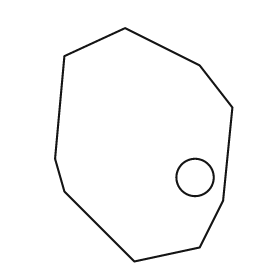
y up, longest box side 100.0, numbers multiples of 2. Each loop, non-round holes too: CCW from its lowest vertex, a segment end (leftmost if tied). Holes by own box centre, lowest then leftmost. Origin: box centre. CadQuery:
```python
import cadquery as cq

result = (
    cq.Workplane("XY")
    .moveTo(-4.0, -50.0)
    .lineTo(24.0, -44.0)
    .lineTo(34.0, -24.0)
    .lineTo(38.0, 16.0)
    .lineTo(24.0, 34.0)
    .lineTo(-8.0, 50.0)
    .lineTo(-34.0, 38.0)
    .lineTo(-38.0, -6.0)
    .lineTo(-34.0, -20.0)
    .close()
    .moveTo(22.0, -14.0)
    .circle(8.0)
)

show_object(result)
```